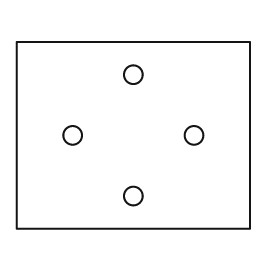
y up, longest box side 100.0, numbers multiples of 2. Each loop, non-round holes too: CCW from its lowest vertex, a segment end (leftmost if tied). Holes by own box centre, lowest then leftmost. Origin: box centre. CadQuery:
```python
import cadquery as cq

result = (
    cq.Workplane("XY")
    .moveTo(-50.0, -40.0)
    .lineTo(50.0, -40.0)
    .lineTo(50.0, 40.0)
    .lineTo(-50.0, 40.0)
    .close()
    .moveTo(0.0, -26.0)
    .circle(4.0)
    .moveTo(-26.0, 0.0)
    .circle(4.0)
    .moveTo(26.0, 0.0)
    .circle(4.0)
    .moveTo(0.0, 26.0)
    .circle(4.0)
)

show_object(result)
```